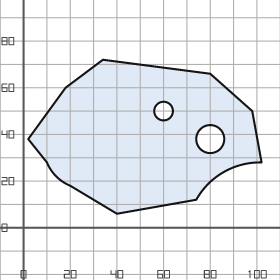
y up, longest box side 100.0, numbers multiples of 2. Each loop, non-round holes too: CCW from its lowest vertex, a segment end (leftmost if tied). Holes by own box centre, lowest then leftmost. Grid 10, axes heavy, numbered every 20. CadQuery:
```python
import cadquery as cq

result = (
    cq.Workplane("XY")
    .moveTo(40.0, 6.0)
    .lineTo(74.0, 12.0)
    .threePointArc((86.0, 24.0), (102.0, 28.0))
    .lineTo(98.0, 50.0)
    .lineTo(80.0, 66.0)
    .lineTo(34.0, 72.0)
    .lineTo(18.0, 60.0)
    .lineTo(2.0, 38.0)
    .lineTo(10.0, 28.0)
    .threePointArc((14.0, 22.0), (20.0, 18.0))
    .close()
    .moveTo(80.0, 38.0)
    .circle(6.0)
    .moveTo(60.0, 50.0)
    .circle(4.0)
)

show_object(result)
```